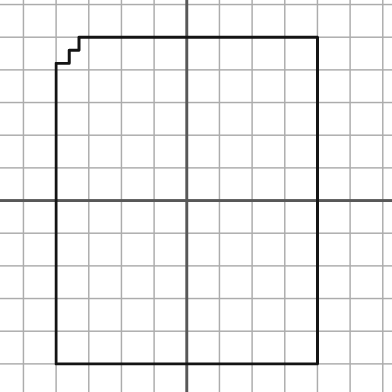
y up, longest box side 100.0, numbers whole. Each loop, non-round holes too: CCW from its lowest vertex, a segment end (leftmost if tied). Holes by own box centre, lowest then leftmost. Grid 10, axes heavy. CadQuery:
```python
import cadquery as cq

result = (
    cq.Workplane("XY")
    .moveTo(-40.0, -50.0)
    .lineTo(40.0, -50.0)
    .lineTo(40.0, 50.0)
    .lineTo(-33.0, 50.0)
    .lineTo(-33.0, 46.0)
    .lineTo(-36.0, 46.0)
    .lineTo(-36.0, 42.0)
    .lineTo(-40.0, 42.0)
    .close()
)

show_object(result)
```